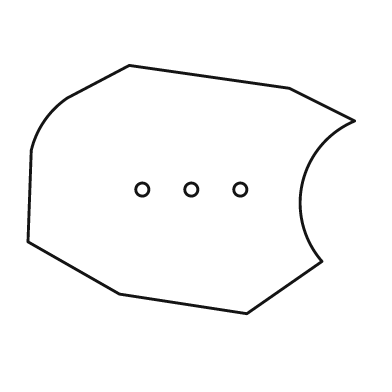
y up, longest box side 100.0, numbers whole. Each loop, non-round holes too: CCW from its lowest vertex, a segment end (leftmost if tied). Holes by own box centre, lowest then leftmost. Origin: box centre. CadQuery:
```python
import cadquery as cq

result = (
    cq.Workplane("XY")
    .moveTo(17.0, -38.0)
    .lineTo(40.0, -22.0)
    .threePointArc((34.0, 2.0), (50.0, 21.0))
    .lineTo(30.0, 31.0)
    .lineTo(-19.0, 38.0)
    .lineTo(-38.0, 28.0)
    .threePointArc((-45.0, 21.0), (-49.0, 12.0))
    .lineTo(-50.0, -16.0)
    .lineTo(-22.0, -32.0)
    .close()
    .moveTo(-15.0, 0.0)
    .circle(2.0)
    .moveTo(0.0, 0.0)
    .circle(2.0)
    .moveTo(15.0, 0.0)
    .circle(2.0)
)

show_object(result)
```